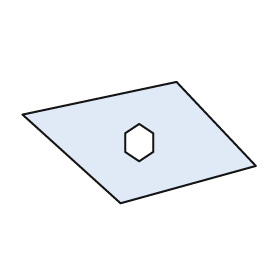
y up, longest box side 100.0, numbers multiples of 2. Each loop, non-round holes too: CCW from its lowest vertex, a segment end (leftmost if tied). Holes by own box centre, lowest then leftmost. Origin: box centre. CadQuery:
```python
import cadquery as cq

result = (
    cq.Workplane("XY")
    .moveTo(-8.0, -26.0)
    .lineTo(50.0, -10.0)
    .lineTo(16.0, 26.0)
    .lineTo(-50.0, 12.0)
    .close()
    .moveTo(0.0, -8.0)
    .lineTo(6.0, -4.0)
    .lineTo(6.0, 4.0)
    .lineTo(0.0, 8.0)
    .lineTo(-6.0, 4.0)
    .lineTo(-6.0, -4.0)
    .close()
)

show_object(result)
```